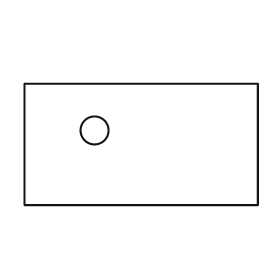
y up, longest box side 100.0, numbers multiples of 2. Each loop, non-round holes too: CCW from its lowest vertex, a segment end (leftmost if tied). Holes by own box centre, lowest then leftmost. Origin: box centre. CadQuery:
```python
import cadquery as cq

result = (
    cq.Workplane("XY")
    .moveTo(-50.0, -26.0)
    .lineTo(50.0, -26.0)
    .lineTo(50.0, 26.0)
    .lineTo(-50.0, 26.0)
    .close()
    .moveTo(-20.0, 6.0)
    .circle(6.0)
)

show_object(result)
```